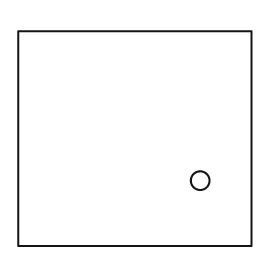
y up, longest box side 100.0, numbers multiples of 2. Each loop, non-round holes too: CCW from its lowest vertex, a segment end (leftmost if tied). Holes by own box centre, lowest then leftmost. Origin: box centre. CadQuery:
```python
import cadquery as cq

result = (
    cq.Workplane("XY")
    .moveTo(-50.0, -46.0)
    .lineTo(50.0, -46.0)
    .lineTo(50.0, 46.0)
    .lineTo(-50.0, 46.0)
    .close()
    .moveTo(28.0, -18.0)
    .circle(4.0)
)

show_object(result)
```